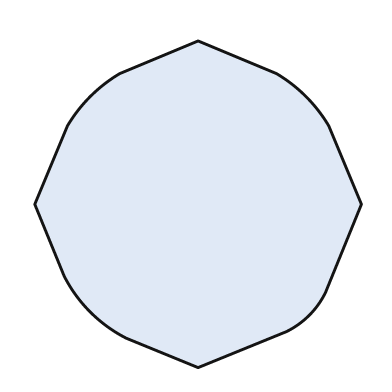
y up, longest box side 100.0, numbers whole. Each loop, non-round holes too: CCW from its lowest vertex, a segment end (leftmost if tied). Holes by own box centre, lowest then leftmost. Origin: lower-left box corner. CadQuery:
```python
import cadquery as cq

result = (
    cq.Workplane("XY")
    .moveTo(50.0, 0.0)
    .lineTo(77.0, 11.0)
    .threePointArc((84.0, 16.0), (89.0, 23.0))
    .lineTo(100.0, 50.0)
    .lineTo(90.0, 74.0)
    .threePointArc((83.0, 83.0), (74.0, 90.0))
    .lineTo(50.0, 100.0)
    .lineTo(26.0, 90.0)
    .threePointArc((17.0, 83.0), (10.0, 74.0))
    .lineTo(0.0, 50.0)
    .lineTo(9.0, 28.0)
    .threePointArc((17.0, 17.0), (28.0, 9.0))
    .close()
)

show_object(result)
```